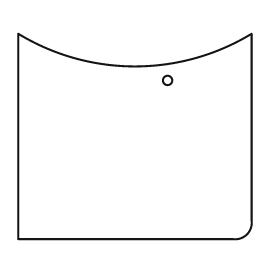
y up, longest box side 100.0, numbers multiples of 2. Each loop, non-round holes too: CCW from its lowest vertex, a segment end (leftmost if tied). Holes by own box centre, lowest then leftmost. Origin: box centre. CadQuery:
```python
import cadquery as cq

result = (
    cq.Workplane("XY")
    .moveTo(-50.0, -44.0)
    .lineTo(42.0, -44.0)
    .threePointArc((48.0, -42.0), (50.0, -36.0))
    .lineTo(50.0, 44.0)
    .threePointArc((0.0, 30.0), (-50.0, 44.0))
    .close()
    .moveTo(14.0, 24.0)
    .circle(2.0)
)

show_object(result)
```